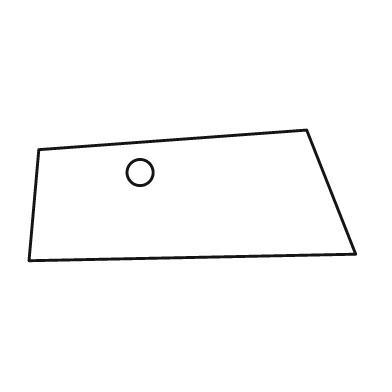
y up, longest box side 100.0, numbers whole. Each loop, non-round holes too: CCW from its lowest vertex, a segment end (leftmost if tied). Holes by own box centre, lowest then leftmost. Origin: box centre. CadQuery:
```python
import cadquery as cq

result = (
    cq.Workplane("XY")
    .moveTo(-50.0, -20.0)
    .lineTo(50.0, -18.0)
    .lineTo(35.0, 20.0)
    .lineTo(-47.0, 14.0)
    .close()
    .moveTo(-16.0, 7.0)
    .circle(4.0)
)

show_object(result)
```